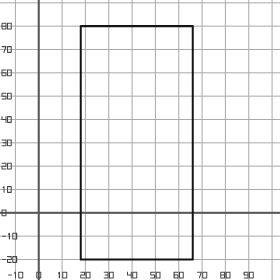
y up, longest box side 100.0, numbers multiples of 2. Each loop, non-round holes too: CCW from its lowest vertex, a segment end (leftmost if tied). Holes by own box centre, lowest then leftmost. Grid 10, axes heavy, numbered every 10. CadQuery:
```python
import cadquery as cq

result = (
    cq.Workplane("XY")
    .moveTo(18.0, -20.0)
    .lineTo(66.0, -20.0)
    .lineTo(66.0, 80.0)
    .lineTo(18.0, 80.0)
    .close()
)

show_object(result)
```